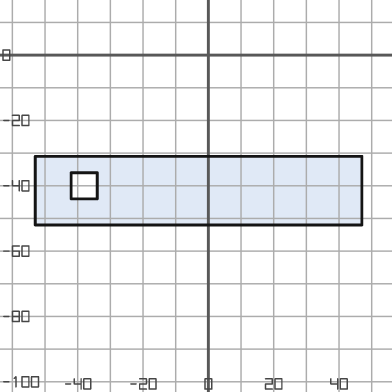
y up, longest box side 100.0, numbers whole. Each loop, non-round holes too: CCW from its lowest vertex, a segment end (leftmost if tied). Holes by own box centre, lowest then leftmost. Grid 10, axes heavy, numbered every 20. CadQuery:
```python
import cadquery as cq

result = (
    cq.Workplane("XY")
    .moveTo(-53.0, -52.0)
    .lineTo(47.0, -52.0)
    .lineTo(47.0, -31.0)
    .lineTo(-53.0, -31.0)
    .close()
    .moveTo(-42.0, -44.0)
    .lineTo(-34.0, -44.0)
    .lineTo(-34.0, -36.0)
    .lineTo(-42.0, -36.0)
    .close()
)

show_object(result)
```